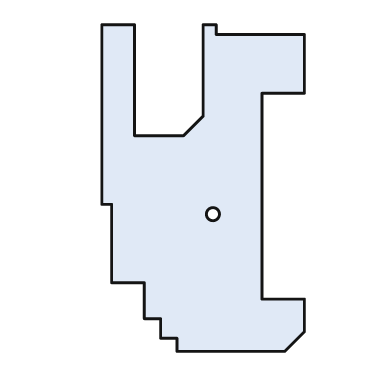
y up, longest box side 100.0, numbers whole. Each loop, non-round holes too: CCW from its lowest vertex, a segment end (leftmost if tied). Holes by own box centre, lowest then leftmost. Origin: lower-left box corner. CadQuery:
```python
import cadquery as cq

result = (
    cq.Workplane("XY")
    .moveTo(23.0, 0.0)
    .lineTo(56.0, 0.0)
    .lineTo(62.0, 6.0)
    .lineTo(62.0, 16.0)
    .lineTo(49.0, 16.0)
    .lineTo(49.0, 79.0)
    .lineTo(62.0, 79.0)
    .lineTo(62.0, 97.0)
    .lineTo(35.0, 97.0)
    .lineTo(35.0, 100.0)
    .lineTo(31.0, 100.0)
    .lineTo(31.0, 72.0)
    .lineTo(25.0, 66.0)
    .lineTo(10.0, 66.0)
    .lineTo(10.0, 100.0)
    .lineTo(0.0, 100.0)
    .lineTo(0.0, 45.0)
    .lineTo(3.0, 45.0)
    .lineTo(3.0, 21.0)
    .lineTo(13.0, 21.0)
    .lineTo(13.0, 10.0)
    .lineTo(18.0, 10.0)
    .lineTo(18.0, 4.0)
    .lineTo(23.0, 4.0)
    .close()
    .moveTo(34.0, 42.0)
    .circle(2.0)
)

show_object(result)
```